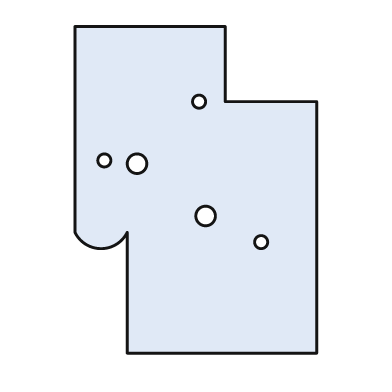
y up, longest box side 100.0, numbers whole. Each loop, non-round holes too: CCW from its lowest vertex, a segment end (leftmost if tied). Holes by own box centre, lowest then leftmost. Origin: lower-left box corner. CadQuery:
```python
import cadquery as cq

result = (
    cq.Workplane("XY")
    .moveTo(16.0, 0.0)
    .lineTo(74.0, 0.0)
    .lineTo(74.0, 77.0)
    .lineTo(46.0, 77.0)
    .lineTo(46.0, 100.0)
    .lineTo(0.0, 100.0)
    .lineTo(0.0, 37.0)
    .threePointArc((8.0, 32.0), (16.0, 37.0))
    .close()
    .moveTo(57.0, 34.0)
    .circle(2.0)
    .moveTo(40.0, 42.0)
    .circle(3.0)
    .moveTo(19.0, 58.0)
    .circle(3.0)
    .moveTo(9.0, 59.0)
    .circle(2.0)
    .moveTo(38.0, 77.0)
    .circle(2.0)
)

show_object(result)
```